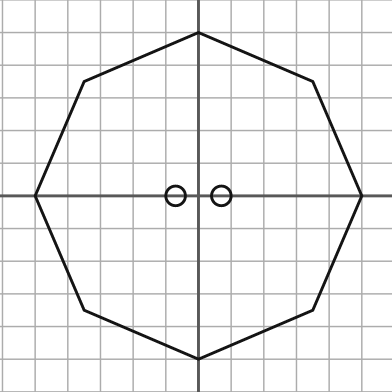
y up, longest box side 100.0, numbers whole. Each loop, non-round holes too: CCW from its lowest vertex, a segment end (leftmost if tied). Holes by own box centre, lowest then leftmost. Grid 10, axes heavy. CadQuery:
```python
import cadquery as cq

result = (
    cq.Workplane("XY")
    .moveTo(0.0, -50.0)
    .lineTo(35.0, -35.0)
    .lineTo(50.0, 0.0)
    .lineTo(35.0, 35.0)
    .lineTo(0.0, 50.0)
    .lineTo(-35.0, 35.0)
    .lineTo(-50.0, 0.0)
    .lineTo(-35.0, -35.0)
    .close()
    .moveTo(-7.0, 0.0)
    .circle(3.0)
    .moveTo(7.0, 0.0)
    .circle(3.0)
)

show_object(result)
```